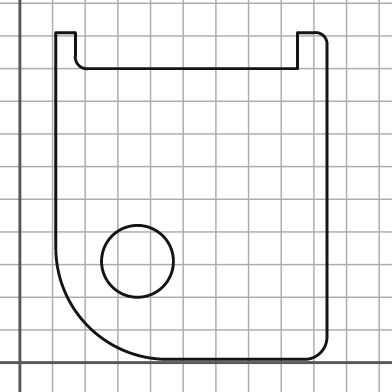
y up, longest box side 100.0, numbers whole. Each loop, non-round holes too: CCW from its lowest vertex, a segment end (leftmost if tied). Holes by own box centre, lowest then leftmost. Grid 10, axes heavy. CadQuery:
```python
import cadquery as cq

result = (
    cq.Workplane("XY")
    .moveTo(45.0, 1.0)
    .lineTo(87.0, 1.0)
    .threePointArc((92.0, 3.0), (94.0, 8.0))
    .lineTo(94.0, 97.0)
    .threePointArc((93.0, 100.0), (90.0, 101.0))
    .lineTo(85.0, 101.0)
    .lineTo(85.0, 90.0)
    .lineTo(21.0, 90.0)
    .threePointArc((18.0, 91.0), (17.0, 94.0))
    .lineTo(17.0, 101.0)
    .lineTo(11.0, 101.0)
    .lineTo(11.0, 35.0)
    .threePointArc((21.0, 11.0), (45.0, 1.0))
    .close()
    .moveTo(36.0, 31.0)
    .circle(11.0)
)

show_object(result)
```